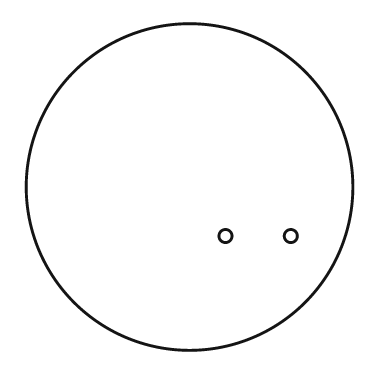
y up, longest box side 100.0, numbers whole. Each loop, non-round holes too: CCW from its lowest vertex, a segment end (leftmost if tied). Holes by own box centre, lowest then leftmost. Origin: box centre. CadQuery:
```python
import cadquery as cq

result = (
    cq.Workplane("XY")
    .moveTo(0.0, 0.0)
    .circle(50.0)
    .moveTo(11.0, -15.0)
    .circle(2.0)
    .moveTo(31.0, -15.0)
    .circle(2.0)
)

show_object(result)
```